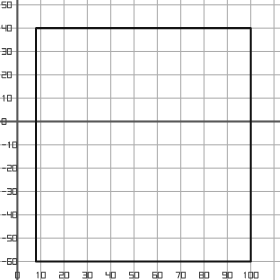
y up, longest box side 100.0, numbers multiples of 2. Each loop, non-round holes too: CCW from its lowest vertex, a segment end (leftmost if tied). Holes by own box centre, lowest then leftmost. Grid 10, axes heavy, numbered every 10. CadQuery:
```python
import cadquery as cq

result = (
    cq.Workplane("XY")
    .moveTo(8.0, -60.0)
    .lineTo(100.0, -60.0)
    .lineTo(100.0, 40.0)
    .lineTo(8.0, 40.0)
    .close()
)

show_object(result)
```